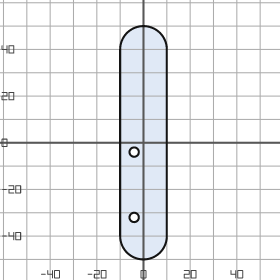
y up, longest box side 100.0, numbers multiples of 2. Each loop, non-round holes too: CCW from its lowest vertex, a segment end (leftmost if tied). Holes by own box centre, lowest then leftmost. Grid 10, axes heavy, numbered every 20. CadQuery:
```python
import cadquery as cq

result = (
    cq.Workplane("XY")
    .moveTo(-10.0, -40.0)
    .threePointArc((0.0, -50.0), (10.0, -40.0))
    .lineTo(10.0, 40.0)
    .threePointArc((0.0, 50.0), (-10.0, 40.0))
    .close()
    .moveTo(-4.0, -32.0)
    .circle(2.0)
    .moveTo(-4.0, -4.0)
    .circle(2.0)
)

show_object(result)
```